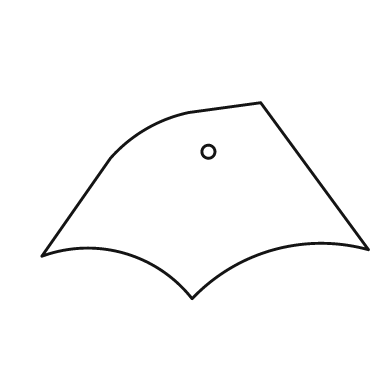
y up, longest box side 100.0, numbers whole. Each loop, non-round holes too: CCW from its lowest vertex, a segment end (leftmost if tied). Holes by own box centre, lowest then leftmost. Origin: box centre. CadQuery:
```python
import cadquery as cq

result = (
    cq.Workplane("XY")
    .moveTo(-4.0, -30.0)
    .threePointArc((21.0, -15.0), (50.0, -15.0))
    .lineTo(17.0, 30.0)
    .lineTo(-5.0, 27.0)
    .threePointArc((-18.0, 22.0), (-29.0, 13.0))
    .lineTo(-50.0, -17.0)
    .threePointArc((-25.0, -16.0), (-4.0, -30.0))
    .close()
    .moveTo(1.0, 15.0)
    .circle(2.0)
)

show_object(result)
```